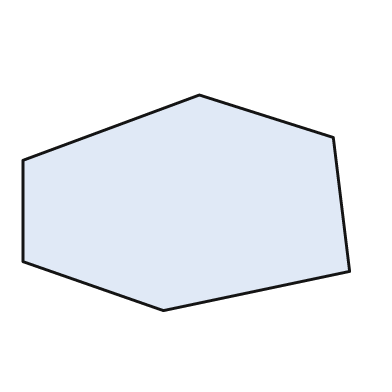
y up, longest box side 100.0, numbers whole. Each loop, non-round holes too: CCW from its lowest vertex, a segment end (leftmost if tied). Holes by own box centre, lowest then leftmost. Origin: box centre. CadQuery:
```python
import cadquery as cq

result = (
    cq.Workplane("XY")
    .moveTo(-7.0, -33.0)
    .lineTo(50.0, -21.0)
    .lineTo(45.0, 20.0)
    .lineTo(4.0, 33.0)
    .lineTo(-50.0, 13.0)
    .lineTo(-50.0, -18.0)
    .close()
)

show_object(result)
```